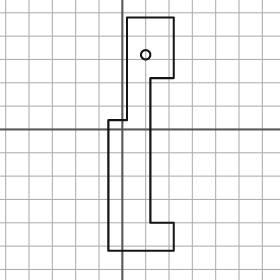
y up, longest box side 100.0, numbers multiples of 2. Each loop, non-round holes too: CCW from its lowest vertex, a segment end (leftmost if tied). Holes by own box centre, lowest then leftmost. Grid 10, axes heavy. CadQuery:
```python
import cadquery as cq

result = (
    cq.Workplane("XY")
    .moveTo(-6.0, -52.0)
    .lineTo(22.0, -52.0)
    .lineTo(22.0, -40.0)
    .lineTo(12.0, -40.0)
    .lineTo(12.0, 22.0)
    .lineTo(22.0, 22.0)
    .lineTo(22.0, 48.0)
    .lineTo(2.0, 48.0)
    .lineTo(2.0, 4.0)
    .lineTo(-6.0, 4.0)
    .close()
    .moveTo(10.0, 32.0)
    .circle(2.0)
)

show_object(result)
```